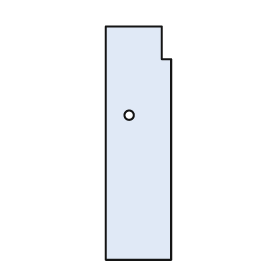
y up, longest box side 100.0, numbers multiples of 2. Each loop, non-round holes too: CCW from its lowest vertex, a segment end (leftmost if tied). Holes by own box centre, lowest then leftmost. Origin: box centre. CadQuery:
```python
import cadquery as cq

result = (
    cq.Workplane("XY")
    .moveTo(-14.0, -50.0)
    .lineTo(14.0, -50.0)
    .lineTo(14.0, 36.0)
    .lineTo(10.0, 36.0)
    .lineTo(10.0, 50.0)
    .lineTo(-14.0, 50.0)
    .close()
    .moveTo(-4.0, 12.0)
    .circle(2.0)
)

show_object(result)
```